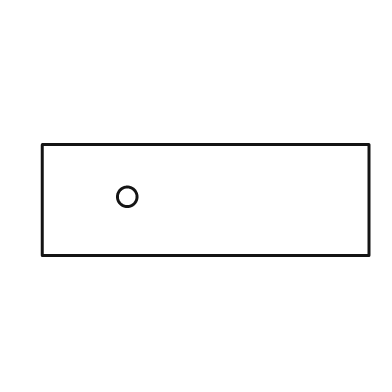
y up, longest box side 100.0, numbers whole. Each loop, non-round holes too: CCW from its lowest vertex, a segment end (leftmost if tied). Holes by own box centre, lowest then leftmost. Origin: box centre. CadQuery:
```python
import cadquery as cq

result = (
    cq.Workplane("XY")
    .moveTo(-50.0, -17.0)
    .lineTo(50.0, -17.0)
    .lineTo(50.0, 17.0)
    .lineTo(-50.0, 17.0)
    .close()
    .moveTo(-24.0, 1.0)
    .circle(3.0)
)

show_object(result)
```